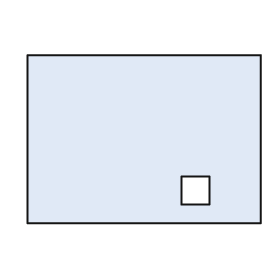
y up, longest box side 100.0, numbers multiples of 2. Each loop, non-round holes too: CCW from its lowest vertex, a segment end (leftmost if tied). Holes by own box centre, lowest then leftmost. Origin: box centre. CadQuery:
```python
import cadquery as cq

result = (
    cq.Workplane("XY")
    .moveTo(-50.0, -36.0)
    .lineTo(50.0, -36.0)
    .lineTo(50.0, 36.0)
    .lineTo(-50.0, 36.0)
    .close()
    .moveTo(16.0, -28.0)
    .lineTo(28.0, -28.0)
    .lineTo(28.0, -16.0)
    .lineTo(16.0, -16.0)
    .close()
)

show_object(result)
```